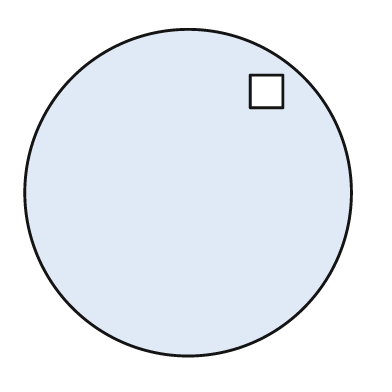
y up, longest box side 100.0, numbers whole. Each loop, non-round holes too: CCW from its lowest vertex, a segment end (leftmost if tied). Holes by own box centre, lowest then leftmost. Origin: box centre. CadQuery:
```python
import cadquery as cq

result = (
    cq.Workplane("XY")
    .moveTo(0.0, 0.0)
    .circle(50.0)
    .moveTo(19.0, 26.0)
    .lineTo(29.0, 26.0)
    .lineTo(29.0, 36.0)
    .lineTo(19.0, 36.0)
    .close()
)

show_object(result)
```